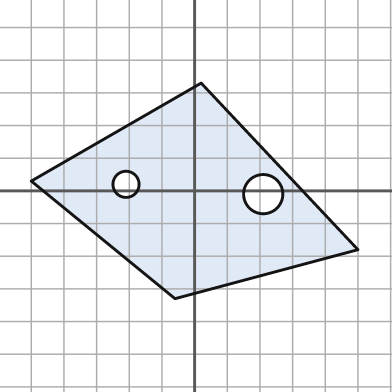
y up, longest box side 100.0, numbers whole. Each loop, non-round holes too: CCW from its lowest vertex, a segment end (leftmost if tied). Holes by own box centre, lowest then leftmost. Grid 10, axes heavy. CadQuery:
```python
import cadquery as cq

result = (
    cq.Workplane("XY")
    .moveTo(-6.0, -33.0)
    .lineTo(50.0, -18.0)
    .lineTo(2.0, 33.0)
    .lineTo(-50.0, 3.0)
    .close()
    .moveTo(21.0, -1.0)
    .circle(6.0)
    .moveTo(-21.0, 2.0)
    .circle(4.0)
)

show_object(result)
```